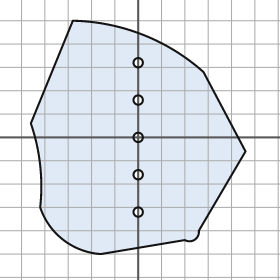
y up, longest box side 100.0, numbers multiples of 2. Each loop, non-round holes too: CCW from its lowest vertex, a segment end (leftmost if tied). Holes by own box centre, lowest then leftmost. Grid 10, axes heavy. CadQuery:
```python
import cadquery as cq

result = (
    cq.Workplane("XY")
    .moveTo(-16.0, -50.0)
    .lineTo(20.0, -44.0)
    .threePointArc((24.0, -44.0), (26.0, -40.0))
    .lineTo(46.0, -6.0)
    .lineTo(28.0, 28.0)
    .threePointArc((2.0, 44.0), (-28.0, 50.0))
    .lineTo(-46.0, 6.0)
    .threePointArc((-42.0, -12.0), (-42.0, -30.0))
    .threePointArc((-32.0, -44.0), (-16.0, -50.0))
    .close()
    .moveTo(0.0, -32.0)
    .circle(2.0)
    .moveTo(0.0, -16.0)
    .circle(2.0)
    .moveTo(0.0, 0.0)
    .circle(2.0)
    .moveTo(0.0, 16.0)
    .circle(2.0)
    .moveTo(0.0, 32.0)
    .circle(2.0)
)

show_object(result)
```